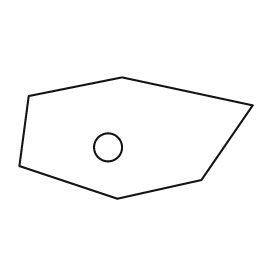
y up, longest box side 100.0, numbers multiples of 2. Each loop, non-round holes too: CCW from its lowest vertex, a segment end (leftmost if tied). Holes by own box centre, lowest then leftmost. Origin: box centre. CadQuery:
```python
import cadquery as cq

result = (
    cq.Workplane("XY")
    .moveTo(-8.0, -26.0)
    .lineTo(28.0, -18.0)
    .lineTo(50.0, 14.0)
    .lineTo(-6.0, 26.0)
    .lineTo(-46.0, 18.0)
    .lineTo(-50.0, -12.0)
    .close()
    .moveTo(-12.0, -4.0)
    .circle(6.0)
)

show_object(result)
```